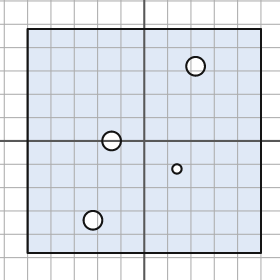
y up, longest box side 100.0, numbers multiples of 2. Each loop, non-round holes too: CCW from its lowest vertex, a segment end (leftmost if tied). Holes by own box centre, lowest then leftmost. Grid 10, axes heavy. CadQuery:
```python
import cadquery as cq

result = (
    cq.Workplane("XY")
    .moveTo(-50.0, -48.0)
    .lineTo(50.0, -48.0)
    .lineTo(50.0, 48.0)
    .lineTo(-50.0, 48.0)
    .close()
    .moveTo(-22.0, -34.0)
    .circle(4.0)
    .moveTo(14.0, -12.0)
    .circle(2.0)
    .moveTo(-14.0, 0.0)
    .circle(4.0)
    .moveTo(22.0, 32.0)
    .circle(4.0)
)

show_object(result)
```